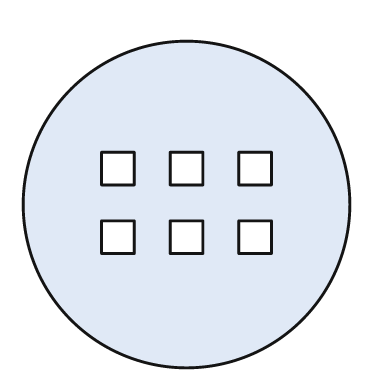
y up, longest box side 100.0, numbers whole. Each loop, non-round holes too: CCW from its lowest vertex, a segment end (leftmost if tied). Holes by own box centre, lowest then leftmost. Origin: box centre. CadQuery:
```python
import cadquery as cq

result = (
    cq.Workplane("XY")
    .moveTo(0.0, 0.0)
    .circle(50.0)
    .moveTo(-26.0, -15.0)
    .lineTo(-16.0, -15.0)
    .lineTo(-16.0, -5.0)
    .lineTo(-26.0, -5.0)
    .close()
    .moveTo(-5.0, -15.0)
    .lineTo(5.0, -15.0)
    .lineTo(5.0, -5.0)
    .lineTo(-5.0, -5.0)
    .close()
    .moveTo(16.0, -15.0)
    .lineTo(26.0, -15.0)
    .lineTo(26.0, -5.0)
    .lineTo(16.0, -5.0)
    .close()
    .moveTo(-26.0, 6.0)
    .lineTo(-16.0, 6.0)
    .lineTo(-16.0, 16.0)
    .lineTo(-26.0, 16.0)
    .close()
    .moveTo(-5.0, 6.0)
    .lineTo(5.0, 6.0)
    .lineTo(5.0, 16.0)
    .lineTo(-5.0, 16.0)
    .close()
    .moveTo(16.0, 6.0)
    .lineTo(26.0, 6.0)
    .lineTo(26.0, 16.0)
    .lineTo(16.0, 16.0)
    .close()
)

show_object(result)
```